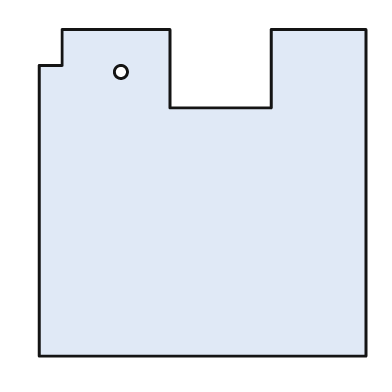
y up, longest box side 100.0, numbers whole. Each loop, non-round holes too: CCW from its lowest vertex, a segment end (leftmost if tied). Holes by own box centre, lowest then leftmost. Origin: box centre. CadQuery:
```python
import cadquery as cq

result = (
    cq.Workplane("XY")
    .moveTo(-50.0, -50.0)
    .lineTo(50.0, -50.0)
    .lineTo(50.0, 50.0)
    .lineTo(21.0, 50.0)
    .lineTo(21.0, 26.0)
    .lineTo(-10.0, 26.0)
    .lineTo(-10.0, 50.0)
    .lineTo(-43.0, 50.0)
    .lineTo(-43.0, 39.0)
    .lineTo(-50.0, 39.0)
    .close()
    .moveTo(-25.0, 37.0)
    .circle(2.0)
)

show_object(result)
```